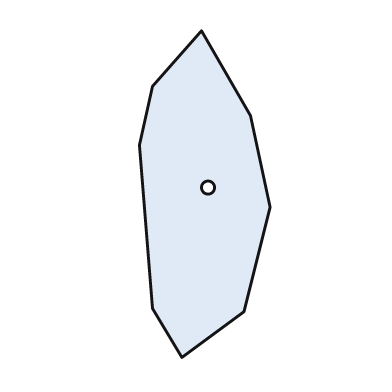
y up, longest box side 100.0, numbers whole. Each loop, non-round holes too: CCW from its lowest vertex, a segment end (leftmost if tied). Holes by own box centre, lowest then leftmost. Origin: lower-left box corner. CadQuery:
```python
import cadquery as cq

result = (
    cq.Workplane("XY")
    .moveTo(13.0, 0.0)
    .lineTo(32.0, 14.0)
    .lineTo(40.0, 46.0)
    .lineTo(34.0, 74.0)
    .lineTo(19.0, 100.0)
    .lineTo(4.0, 83.0)
    .lineTo(0.0, 65.0)
    .lineTo(4.0, 15.0)
    .close()
    .moveTo(21.0, 52.0)
    .circle(2.0)
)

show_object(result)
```